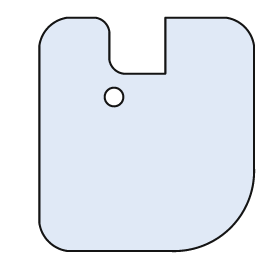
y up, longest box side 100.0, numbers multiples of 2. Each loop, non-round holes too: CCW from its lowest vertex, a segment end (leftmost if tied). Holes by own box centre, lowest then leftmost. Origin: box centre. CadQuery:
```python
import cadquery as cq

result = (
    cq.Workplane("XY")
    .moveTo(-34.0, -50.0)
    .lineTo(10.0, -50.0)
    .threePointArc((36.0, -40.0), (46.0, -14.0))
    .lineTo(46.0, 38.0)
    .threePointArc((42.0, 46.0), (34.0, 50.0))
    .lineTo(8.0, 50.0)
    .lineTo(8.0, 26.0)
    .lineTo(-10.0, 26.0)
    .threePointArc((-14.0, 28.0), (-16.0, 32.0))
    .lineTo(-16.0, 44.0)
    .threePointArc((-18.0, 48.0), (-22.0, 50.0))
    .lineTo(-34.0, 50.0)
    .threePointArc((-42.0, 46.0), (-46.0, 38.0))
    .lineTo(-46.0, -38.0)
    .threePointArc((-42.0, -46.0), (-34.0, -50.0))
    .close()
    .moveTo(-14.0, 16.0)
    .circle(4.0)
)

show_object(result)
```